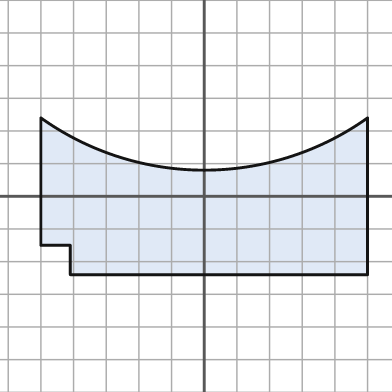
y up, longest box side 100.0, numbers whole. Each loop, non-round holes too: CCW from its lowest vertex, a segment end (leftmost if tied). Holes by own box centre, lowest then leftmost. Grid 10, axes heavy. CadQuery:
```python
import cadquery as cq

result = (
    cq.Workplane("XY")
    .moveTo(-41.0, -24.0)
    .lineTo(50.0, -24.0)
    .lineTo(50.0, 24.0)
    .threePointArc((0.0, 8.0), (-50.0, 24.0))
    .lineTo(-50.0, -15.0)
    .lineTo(-41.0, -15.0)
    .close()
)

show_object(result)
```